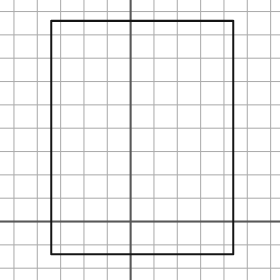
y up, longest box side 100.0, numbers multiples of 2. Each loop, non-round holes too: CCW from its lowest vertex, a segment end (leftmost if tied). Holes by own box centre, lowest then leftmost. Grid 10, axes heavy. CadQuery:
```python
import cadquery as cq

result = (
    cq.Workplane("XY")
    .moveTo(-34.0, -14.0)
    .lineTo(44.0, -14.0)
    .lineTo(44.0, 86.0)
    .lineTo(-34.0, 86.0)
    .close()
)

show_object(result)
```